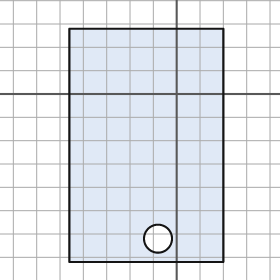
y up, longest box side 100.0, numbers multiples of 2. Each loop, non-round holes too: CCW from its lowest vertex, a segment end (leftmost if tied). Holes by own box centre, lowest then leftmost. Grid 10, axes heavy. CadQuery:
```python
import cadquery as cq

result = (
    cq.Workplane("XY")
    .moveTo(-46.0, -72.0)
    .lineTo(20.0, -72.0)
    .lineTo(20.0, 28.0)
    .lineTo(-46.0, 28.0)
    .close()
    .moveTo(-8.0, -62.0)
    .circle(6.0)
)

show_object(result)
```